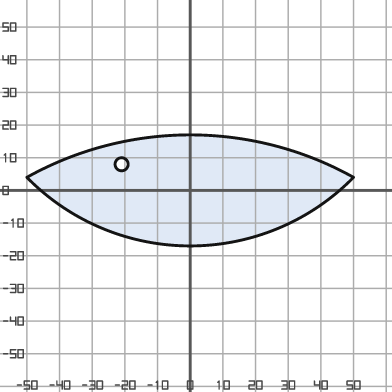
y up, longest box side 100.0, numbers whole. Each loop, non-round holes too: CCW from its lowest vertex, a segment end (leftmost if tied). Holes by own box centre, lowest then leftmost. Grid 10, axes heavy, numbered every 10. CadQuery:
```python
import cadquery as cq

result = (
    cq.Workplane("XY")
    .moveTo(-50.0, 4.0)
    .threePointArc((0.0, -17.0), (50.0, 4.0))
    .threePointArc((0.0, 17.0), (-50.0, 4.0))
    .close()
    .moveTo(-21.0, 8.0)
    .circle(2.0)
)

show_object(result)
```